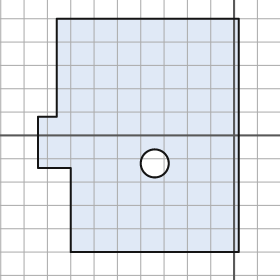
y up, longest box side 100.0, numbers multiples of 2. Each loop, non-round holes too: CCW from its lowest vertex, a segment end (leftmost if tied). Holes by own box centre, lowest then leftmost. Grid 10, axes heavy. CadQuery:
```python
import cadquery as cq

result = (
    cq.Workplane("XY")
    .moveTo(-70.0, -50.0)
    .lineTo(2.0, -50.0)
    .lineTo(2.0, 50.0)
    .lineTo(-76.0, 50.0)
    .lineTo(-76.0, 8.0)
    .lineTo(-84.0, 8.0)
    .lineTo(-84.0, -14.0)
    .lineTo(-70.0, -14.0)
    .close()
    .moveTo(-34.0, -12.0)
    .circle(6.0)
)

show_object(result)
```